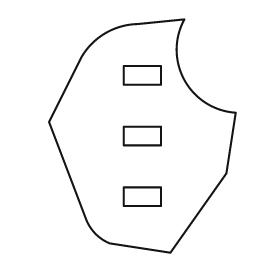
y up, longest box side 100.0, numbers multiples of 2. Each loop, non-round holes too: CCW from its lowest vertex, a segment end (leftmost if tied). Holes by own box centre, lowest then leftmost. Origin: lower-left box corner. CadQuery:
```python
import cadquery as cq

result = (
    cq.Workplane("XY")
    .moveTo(52.0, 0.0)
    .lineTo(76.0, 34.0)
    .lineTo(80.0, 60.0)
    .threePointArc((58.0, 74.0), (58.0, 100.0))
    .lineTo(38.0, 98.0)
    .threePointArc((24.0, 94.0), (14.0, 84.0))
    .lineTo(0.0, 56.0)
    .lineTo(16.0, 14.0)
    .threePointArc((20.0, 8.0), (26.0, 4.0))
    .close()
    .moveTo(32.0, 20.0)
    .lineTo(48.0, 20.0)
    .lineTo(48.0, 28.0)
    .lineTo(32.0, 28.0)
    .close()
    .moveTo(32.0, 46.0)
    .lineTo(48.0, 46.0)
    .lineTo(48.0, 54.0)
    .lineTo(32.0, 54.0)
    .close()
    .moveTo(32.0, 72.0)
    .lineTo(48.0, 72.0)
    .lineTo(48.0, 80.0)
    .lineTo(32.0, 80.0)
    .close()
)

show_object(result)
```